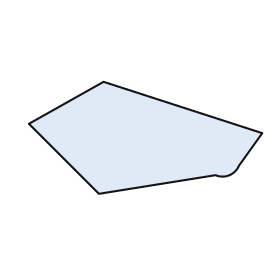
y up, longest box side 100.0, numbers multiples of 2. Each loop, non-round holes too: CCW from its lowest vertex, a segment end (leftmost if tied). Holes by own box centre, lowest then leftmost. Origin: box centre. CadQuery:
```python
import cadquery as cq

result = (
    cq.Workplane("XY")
    .moveTo(-20.0, -24.0)
    .lineTo(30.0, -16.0)
    .threePointArc((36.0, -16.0), (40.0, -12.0))
    .lineTo(50.0, 2.0)
    .lineTo(-18.0, 24.0)
    .lineTo(-50.0, 6.0)
    .close()
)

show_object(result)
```